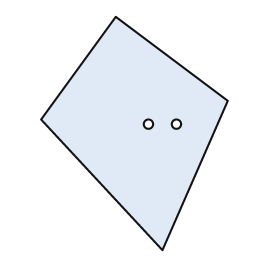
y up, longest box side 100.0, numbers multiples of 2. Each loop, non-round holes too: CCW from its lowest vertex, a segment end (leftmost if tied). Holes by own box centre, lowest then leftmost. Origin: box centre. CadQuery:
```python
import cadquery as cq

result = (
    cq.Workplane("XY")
    .moveTo(12.0, -50.0)
    .lineTo(40.0, 14.0)
    .lineTo(-8.0, 50.0)
    .lineTo(-40.0, 6.0)
    .close()
    .moveTo(6.0, 4.0)
    .circle(2.0)
    .moveTo(18.0, 4.0)
    .circle(2.0)
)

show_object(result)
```